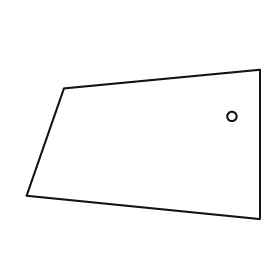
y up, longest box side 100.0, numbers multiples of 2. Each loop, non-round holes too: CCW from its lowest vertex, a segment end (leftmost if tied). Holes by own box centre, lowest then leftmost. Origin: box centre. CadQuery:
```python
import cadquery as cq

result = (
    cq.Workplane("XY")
    .moveTo(50.0, -32.0)
    .lineTo(50.0, 32.0)
    .lineTo(-34.0, 24.0)
    .lineTo(-50.0, -22.0)
    .close()
    .moveTo(38.0, 12.0)
    .circle(2.0)
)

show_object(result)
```